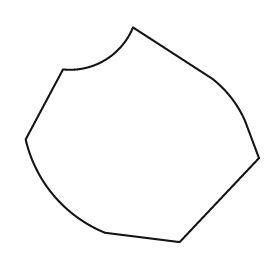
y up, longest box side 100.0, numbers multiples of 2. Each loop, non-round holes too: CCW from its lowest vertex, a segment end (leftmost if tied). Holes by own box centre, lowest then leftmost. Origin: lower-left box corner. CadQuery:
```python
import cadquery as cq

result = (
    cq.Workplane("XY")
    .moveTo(66.0, 0.0)
    .lineTo(100.0, 36.0)
    .lineTo(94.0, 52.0)
    .threePointArc((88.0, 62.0), (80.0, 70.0))
    .lineTo(46.0, 92.0)
    .threePointArc((34.0, 78.0), (16.0, 74.0))
    .lineTo(0.0, 44.0)
    .threePointArc((12.0, 20.0), (34.0, 4.0))
    .close()
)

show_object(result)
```